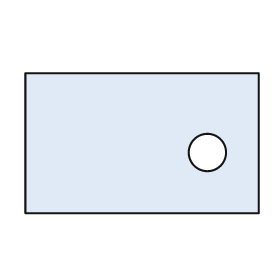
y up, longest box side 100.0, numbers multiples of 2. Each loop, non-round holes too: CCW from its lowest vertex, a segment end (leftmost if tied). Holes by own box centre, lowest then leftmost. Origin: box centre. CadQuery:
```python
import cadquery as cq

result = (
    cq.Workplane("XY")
    .moveTo(-50.0, -30.0)
    .lineTo(50.0, -30.0)
    .lineTo(50.0, 30.0)
    .lineTo(-50.0, 30.0)
    .close()
    .moveTo(28.0, -4.0)
    .circle(8.0)
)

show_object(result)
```